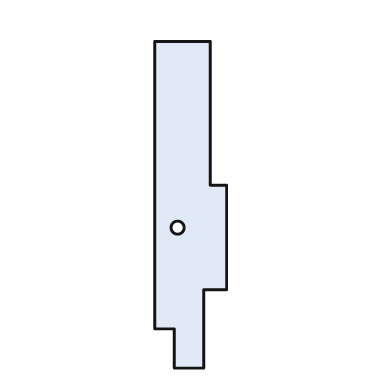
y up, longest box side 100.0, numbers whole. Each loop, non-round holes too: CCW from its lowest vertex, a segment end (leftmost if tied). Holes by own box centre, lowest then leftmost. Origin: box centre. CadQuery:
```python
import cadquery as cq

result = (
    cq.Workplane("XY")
    .moveTo(-5.0, -50.0)
    .lineTo(4.0, -50.0)
    .lineTo(4.0, -26.0)
    .lineTo(11.0, -26.0)
    .lineTo(11.0, 6.0)
    .lineTo(6.0, 6.0)
    .lineTo(6.0, 50.0)
    .lineTo(-11.0, 50.0)
    .lineTo(-11.0, -38.0)
    .lineTo(-5.0, -38.0)
    .close()
    .moveTo(-4.0, -7.0)
    .circle(2.0)
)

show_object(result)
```